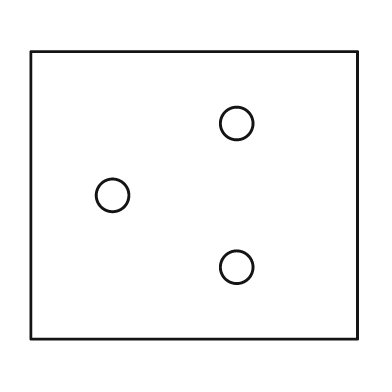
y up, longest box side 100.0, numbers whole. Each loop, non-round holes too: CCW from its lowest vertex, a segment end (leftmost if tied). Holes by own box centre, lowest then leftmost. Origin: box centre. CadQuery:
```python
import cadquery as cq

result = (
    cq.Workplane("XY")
    .moveTo(-50.0, -44.0)
    .lineTo(50.0, -44.0)
    .lineTo(50.0, 44.0)
    .lineTo(-50.0, 44.0)
    .close()
    .moveTo(13.0, -22.0)
    .circle(5.0)
    .moveTo(-25.0, 0.0)
    .circle(5.0)
    .moveTo(13.0, 22.0)
    .circle(5.0)
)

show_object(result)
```